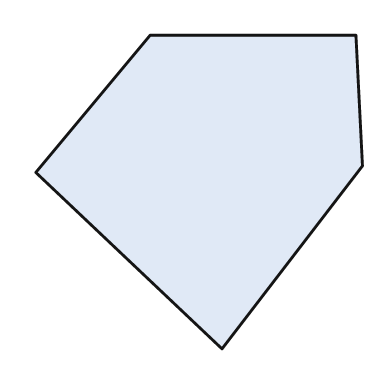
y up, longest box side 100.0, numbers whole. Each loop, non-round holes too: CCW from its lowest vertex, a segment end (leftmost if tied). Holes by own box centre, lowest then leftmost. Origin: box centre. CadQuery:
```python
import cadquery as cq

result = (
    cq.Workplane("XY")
    .moveTo(7.0, -48.0)
    .lineTo(50.0, 8.0)
    .lineTo(48.0, 48.0)
    .lineTo(-15.0, 48.0)
    .lineTo(-50.0, 6.0)
    .close()
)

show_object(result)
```